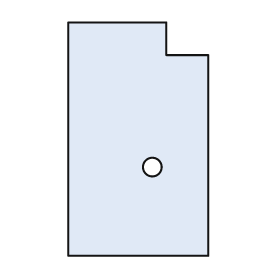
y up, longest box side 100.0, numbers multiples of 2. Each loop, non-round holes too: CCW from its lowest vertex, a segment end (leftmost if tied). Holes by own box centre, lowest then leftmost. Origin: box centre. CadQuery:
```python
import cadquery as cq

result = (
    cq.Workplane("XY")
    .moveTo(-30.0, -50.0)
    .lineTo(30.0, -50.0)
    .lineTo(30.0, 36.0)
    .lineTo(12.0, 36.0)
    .lineTo(12.0, 50.0)
    .lineTo(-30.0, 50.0)
    .close()
    .moveTo(6.0, -12.0)
    .circle(4.0)
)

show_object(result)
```